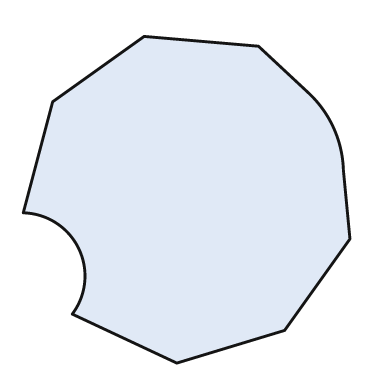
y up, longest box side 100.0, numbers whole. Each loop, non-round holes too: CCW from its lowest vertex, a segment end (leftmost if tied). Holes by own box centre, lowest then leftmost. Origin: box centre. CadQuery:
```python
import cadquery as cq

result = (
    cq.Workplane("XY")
    .moveTo(-3.0, -50.0)
    .lineTo(30.0, -40.0)
    .lineTo(50.0, -12.0)
    .lineTo(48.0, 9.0)
    .threePointArc((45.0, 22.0), (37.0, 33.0))
    .lineTo(22.0, 47.0)
    .lineTo(-13.0, 50.0)
    .lineTo(-41.0, 30.0)
    .lineTo(-50.0, -4.0)
    .threePointArc((-33.0, -15.0), (-35.0, -35.0))
    .close()
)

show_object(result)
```